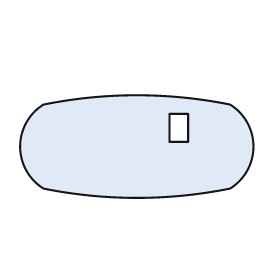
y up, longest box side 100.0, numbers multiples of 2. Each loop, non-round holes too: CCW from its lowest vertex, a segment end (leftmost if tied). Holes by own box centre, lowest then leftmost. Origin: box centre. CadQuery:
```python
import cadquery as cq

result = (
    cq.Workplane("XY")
    .moveTo(-40.0, -18.0)
    .threePointArc((0.0, -22.0), (40.0, -18.0))
    .threePointArc((50.0, 0.0), (40.0, 18.0))
    .threePointArc((0.0, 22.0), (-40.0, 18.0))
    .threePointArc((-50.0, 0.0), (-40.0, -18.0))
    .close()
    .moveTo(14.0, 2.0)
    .lineTo(22.0, 2.0)
    .lineTo(22.0, 14.0)
    .lineTo(14.0, 14.0)
    .close()
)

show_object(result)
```